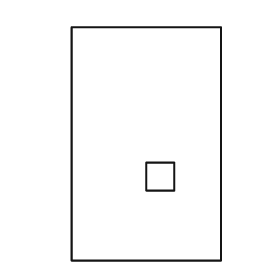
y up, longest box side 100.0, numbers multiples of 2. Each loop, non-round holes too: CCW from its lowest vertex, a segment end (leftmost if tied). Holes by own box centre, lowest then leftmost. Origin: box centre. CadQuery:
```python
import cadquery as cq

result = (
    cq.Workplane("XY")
    .moveTo(-32.0, -50.0)
    .lineTo(32.0, -50.0)
    .lineTo(32.0, 50.0)
    .lineTo(-32.0, 50.0)
    .close()
    .moveTo(0.0, -20.0)
    .lineTo(12.0, -20.0)
    .lineTo(12.0, -8.0)
    .lineTo(0.0, -8.0)
    .close()
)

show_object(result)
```